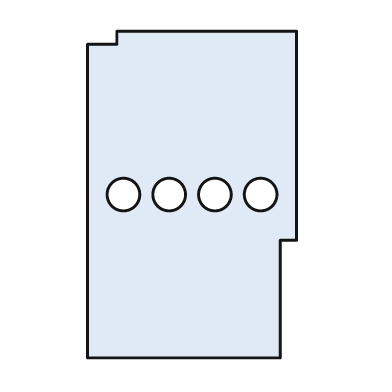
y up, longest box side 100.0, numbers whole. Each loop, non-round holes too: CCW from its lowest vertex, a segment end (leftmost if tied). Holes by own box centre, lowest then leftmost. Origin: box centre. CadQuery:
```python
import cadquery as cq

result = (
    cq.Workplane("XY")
    .moveTo(-32.0, -50.0)
    .lineTo(27.0, -50.0)
    .lineTo(27.0, -14.0)
    .lineTo(32.0, -14.0)
    .lineTo(32.0, 50.0)
    .lineTo(-23.0, 50.0)
    .lineTo(-23.0, 46.0)
    .lineTo(-32.0, 46.0)
    .close()
    .moveTo(-21.0, 0.0)
    .circle(5.0)
    .moveTo(-7.0, 0.0)
    .circle(5.0)
    .moveTo(7.0, 0.0)
    .circle(5.0)
    .moveTo(21.0, 0.0)
    .circle(5.0)
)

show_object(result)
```